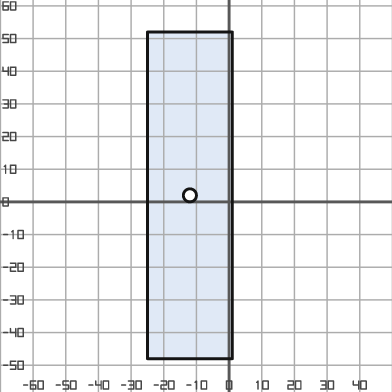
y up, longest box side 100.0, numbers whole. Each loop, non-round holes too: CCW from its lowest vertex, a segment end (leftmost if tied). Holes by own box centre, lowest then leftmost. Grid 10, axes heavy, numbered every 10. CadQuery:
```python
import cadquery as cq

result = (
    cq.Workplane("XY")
    .moveTo(-25.0, -48.0)
    .lineTo(1.0, -48.0)
    .lineTo(1.0, 52.0)
    .lineTo(-25.0, 52.0)
    .close()
    .moveTo(-12.0, 2.0)
    .circle(2.0)
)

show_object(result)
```